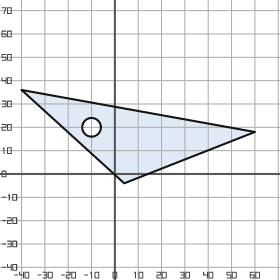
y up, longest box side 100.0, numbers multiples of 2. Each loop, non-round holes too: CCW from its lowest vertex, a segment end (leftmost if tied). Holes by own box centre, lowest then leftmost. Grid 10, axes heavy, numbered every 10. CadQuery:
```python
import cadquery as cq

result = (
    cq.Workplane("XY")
    .moveTo(4.0, -4.0)
    .lineTo(60.0, 18.0)
    .lineTo(-40.0, 36.0)
    .close()
    .moveTo(-10.0, 20.0)
    .circle(4.0)
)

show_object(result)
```